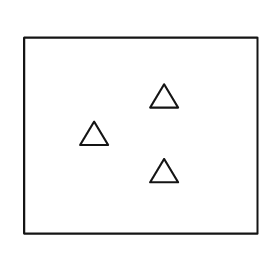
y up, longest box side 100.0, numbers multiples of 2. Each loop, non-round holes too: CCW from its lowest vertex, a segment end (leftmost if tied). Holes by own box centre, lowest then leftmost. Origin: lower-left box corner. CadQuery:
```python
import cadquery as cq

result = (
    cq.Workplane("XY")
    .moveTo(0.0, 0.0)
    .lineTo(100.0, 0.0)
    .lineTo(100.0, 84.0)
    .lineTo(0.0, 84.0)
    .close()
    .moveTo(54.0, 22.0)
    .lineTo(66.0, 22.0)
    .lineTo(60.0, 32.0)
    .close()
    .moveTo(24.0, 38.0)
    .lineTo(36.0, 38.0)
    .lineTo(30.0, 48.0)
    .close()
    .moveTo(54.0, 54.0)
    .lineTo(66.0, 54.0)
    .lineTo(60.0, 64.0)
    .close()
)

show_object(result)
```